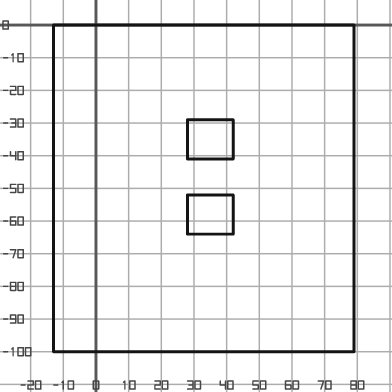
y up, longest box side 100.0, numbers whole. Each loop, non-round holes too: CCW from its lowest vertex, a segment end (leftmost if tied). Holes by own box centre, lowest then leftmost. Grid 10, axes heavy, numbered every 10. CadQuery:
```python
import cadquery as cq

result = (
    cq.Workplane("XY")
    .moveTo(-13.0, -100.0)
    .lineTo(79.0, -100.0)
    .lineTo(79.0, 0.0)
    .lineTo(-13.0, 0.0)
    .close()
    .moveTo(28.0, -64.0)
    .lineTo(42.0, -64.0)
    .lineTo(42.0, -52.0)
    .lineTo(28.0, -52.0)
    .close()
    .moveTo(28.0, -41.0)
    .lineTo(42.0, -41.0)
    .lineTo(42.0, -29.0)
    .lineTo(28.0, -29.0)
    .close()
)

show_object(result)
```